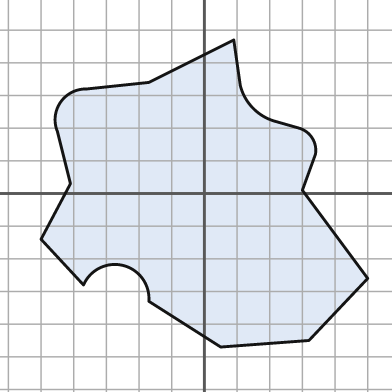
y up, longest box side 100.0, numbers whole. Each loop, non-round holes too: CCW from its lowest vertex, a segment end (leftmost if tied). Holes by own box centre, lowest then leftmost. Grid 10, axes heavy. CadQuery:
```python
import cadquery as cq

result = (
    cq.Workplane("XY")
    .moveTo(5.0, -47.0)
    .lineTo(32.0, -45.0)
    .lineTo(50.0, -26.0)
    .lineTo(30.0, 1.0)
    .lineTo(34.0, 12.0)
    .threePointArc((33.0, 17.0), (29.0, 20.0))
    .lineTo(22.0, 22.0)
    .threePointArc((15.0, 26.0), (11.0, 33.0))
    .lineTo(9.0, 47.0)
    .lineTo(-17.0, 34.0)
    .lineTo(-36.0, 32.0)
    .threePointArc((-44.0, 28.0), (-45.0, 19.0))
    .lineTo(-41.0, 3.0)
    .lineTo(-50.0, -14.0)
    .lineTo(-37.0, -28.0)
    .threePointArc((-25.0, -22.0), (-17.0, -33.0))
    .close()
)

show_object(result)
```